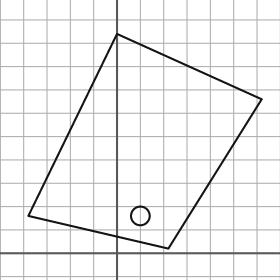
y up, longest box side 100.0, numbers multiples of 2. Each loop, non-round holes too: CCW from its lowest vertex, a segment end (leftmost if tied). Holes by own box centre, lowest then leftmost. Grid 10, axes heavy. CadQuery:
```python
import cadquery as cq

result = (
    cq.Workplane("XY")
    .moveTo(22.0, 2.0)
    .lineTo(62.0, 66.0)
    .lineTo(0.0, 94.0)
    .lineTo(-38.0, 16.0)
    .close()
    .moveTo(10.0, 16.0)
    .circle(4.0)
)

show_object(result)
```